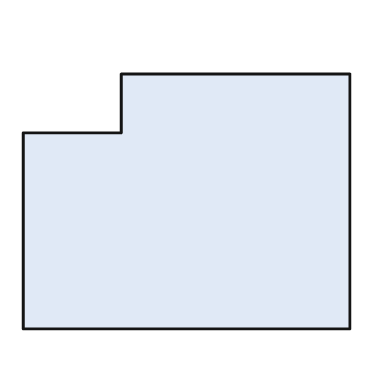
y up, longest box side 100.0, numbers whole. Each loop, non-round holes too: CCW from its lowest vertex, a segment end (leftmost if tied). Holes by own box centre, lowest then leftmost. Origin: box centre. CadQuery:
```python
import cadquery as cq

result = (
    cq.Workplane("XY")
    .moveTo(-50.0, -39.0)
    .lineTo(50.0, -39.0)
    .lineTo(50.0, 39.0)
    .lineTo(-20.0, 39.0)
    .lineTo(-20.0, 21.0)
    .lineTo(-50.0, 21.0)
    .close()
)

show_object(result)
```